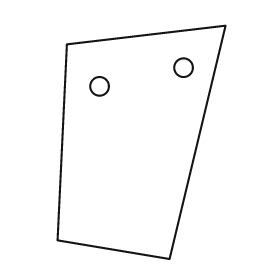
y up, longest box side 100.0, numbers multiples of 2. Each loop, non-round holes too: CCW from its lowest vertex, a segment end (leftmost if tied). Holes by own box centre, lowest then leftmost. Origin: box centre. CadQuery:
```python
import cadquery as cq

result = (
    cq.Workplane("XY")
    .moveTo(12.0, -50.0)
    .lineTo(36.0, 50.0)
    .lineTo(-32.0, 42.0)
    .lineTo(-36.0, -42.0)
    .close()
    .moveTo(-18.0, 24.0)
    .circle(4.0)
    .moveTo(18.0, 32.0)
    .circle(4.0)
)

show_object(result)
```